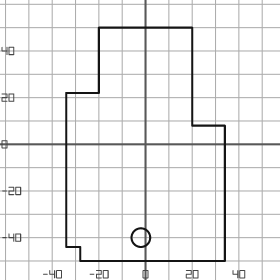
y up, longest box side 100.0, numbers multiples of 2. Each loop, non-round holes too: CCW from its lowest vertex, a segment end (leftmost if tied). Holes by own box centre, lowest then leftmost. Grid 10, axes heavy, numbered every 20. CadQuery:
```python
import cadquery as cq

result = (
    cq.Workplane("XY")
    .moveTo(-28.0, -50.0)
    .lineTo(34.0, -50.0)
    .lineTo(34.0, 8.0)
    .lineTo(20.0, 8.0)
    .lineTo(20.0, 50.0)
    .lineTo(-20.0, 50.0)
    .lineTo(-20.0, 22.0)
    .lineTo(-34.0, 22.0)
    .lineTo(-34.0, -44.0)
    .lineTo(-28.0, -44.0)
    .close()
    .moveTo(-2.0, -40.0)
    .circle(4.0)
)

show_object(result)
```